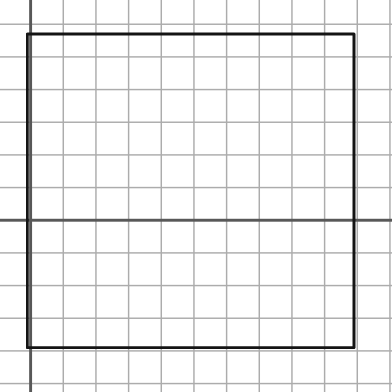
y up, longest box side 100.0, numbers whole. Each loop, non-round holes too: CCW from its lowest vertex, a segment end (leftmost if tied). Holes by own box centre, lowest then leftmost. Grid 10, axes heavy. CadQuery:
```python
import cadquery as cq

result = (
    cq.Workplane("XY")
    .moveTo(-1.0, -39.0)
    .lineTo(99.0, -39.0)
    .lineTo(99.0, 57.0)
    .lineTo(-1.0, 57.0)
    .close()
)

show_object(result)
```